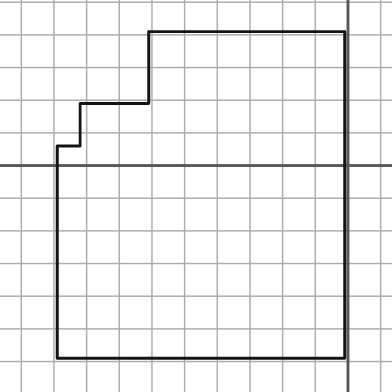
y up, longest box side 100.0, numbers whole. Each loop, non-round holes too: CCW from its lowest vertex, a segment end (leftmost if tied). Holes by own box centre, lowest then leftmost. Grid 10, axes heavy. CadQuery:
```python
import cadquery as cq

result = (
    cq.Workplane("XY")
    .moveTo(-89.0, -59.0)
    .lineTo(-1.0, -59.0)
    .lineTo(-1.0, 41.0)
    .lineTo(-61.0, 41.0)
    .lineTo(-61.0, 19.0)
    .lineTo(-82.0, 19.0)
    .lineTo(-82.0, 6.0)
    .lineTo(-89.0, 6.0)
    .close()
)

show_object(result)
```